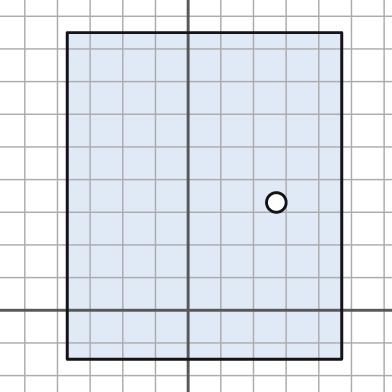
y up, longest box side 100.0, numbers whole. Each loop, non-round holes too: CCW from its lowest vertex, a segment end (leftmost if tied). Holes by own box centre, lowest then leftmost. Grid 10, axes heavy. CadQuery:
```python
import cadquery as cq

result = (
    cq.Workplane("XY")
    .moveTo(-37.0, -15.0)
    .lineTo(47.0, -15.0)
    .lineTo(47.0, 85.0)
    .lineTo(-37.0, 85.0)
    .close()
    .moveTo(27.0, 33.0)
    .circle(3.0)
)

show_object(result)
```